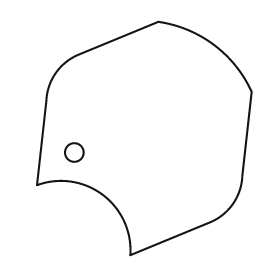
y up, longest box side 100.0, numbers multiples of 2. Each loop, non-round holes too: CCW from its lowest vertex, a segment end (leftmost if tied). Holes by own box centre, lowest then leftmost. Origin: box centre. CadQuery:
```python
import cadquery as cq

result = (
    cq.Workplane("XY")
    .moveTo(-6.0, -50.0)
    .lineTo(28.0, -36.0)
    .threePointArc((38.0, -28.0), (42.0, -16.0))
    .lineTo(46.0, 20.0)
    .threePointArc((30.0, 40.0), (6.0, 50.0))
    .lineTo(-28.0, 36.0)
    .threePointArc((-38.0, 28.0), (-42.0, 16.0))
    .lineTo(-46.0, -20.0)
    .threePointArc((-18.0, -24.0), (-6.0, -50.0))
    .close()
    .moveTo(-30.0, -6.0)
    .circle(4.0)
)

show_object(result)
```